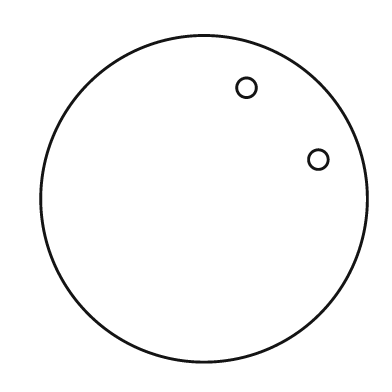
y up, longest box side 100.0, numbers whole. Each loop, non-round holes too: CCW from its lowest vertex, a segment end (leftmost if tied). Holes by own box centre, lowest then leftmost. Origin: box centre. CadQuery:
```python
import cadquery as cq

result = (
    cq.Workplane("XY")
    .moveTo(0.0, 0.0)
    .circle(50.0)
    .moveTo(35.0, 12.0)
    .circle(3.0)
    .moveTo(13.0, 34.0)
    .circle(3.0)
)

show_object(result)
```